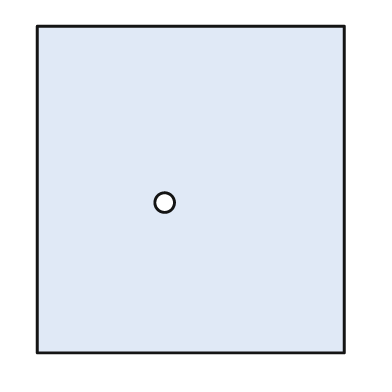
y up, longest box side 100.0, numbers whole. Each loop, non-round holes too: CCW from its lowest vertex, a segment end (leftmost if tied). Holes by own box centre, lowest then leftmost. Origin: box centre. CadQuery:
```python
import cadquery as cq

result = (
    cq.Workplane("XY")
    .moveTo(-47.0, -50.0)
    .lineTo(47.0, -50.0)
    .lineTo(47.0, 50.0)
    .lineTo(-47.0, 50.0)
    .close()
    .moveTo(-8.0, -4.0)
    .circle(3.0)
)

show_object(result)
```